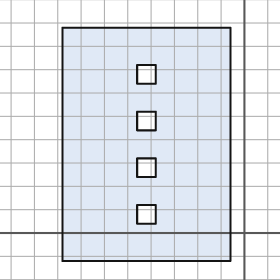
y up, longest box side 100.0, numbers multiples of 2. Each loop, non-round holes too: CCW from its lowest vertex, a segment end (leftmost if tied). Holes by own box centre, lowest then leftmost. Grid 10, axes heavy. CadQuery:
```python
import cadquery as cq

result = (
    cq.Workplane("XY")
    .moveTo(-78.0, -12.0)
    .lineTo(-6.0, -12.0)
    .lineTo(-6.0, 88.0)
    .lineTo(-78.0, 88.0)
    .close()
    .moveTo(-46.0, 4.0)
    .lineTo(-38.0, 4.0)
    .lineTo(-38.0, 12.0)
    .lineTo(-46.0, 12.0)
    .close()
    .moveTo(-46.0, 24.0)
    .lineTo(-38.0, 24.0)
    .lineTo(-38.0, 32.0)
    .lineTo(-46.0, 32.0)
    .close()
    .moveTo(-46.0, 44.0)
    .lineTo(-38.0, 44.0)
    .lineTo(-38.0, 52.0)
    .lineTo(-46.0, 52.0)
    .close()
    .moveTo(-46.0, 64.0)
    .lineTo(-38.0, 64.0)
    .lineTo(-38.0, 72.0)
    .lineTo(-46.0, 72.0)
    .close()
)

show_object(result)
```